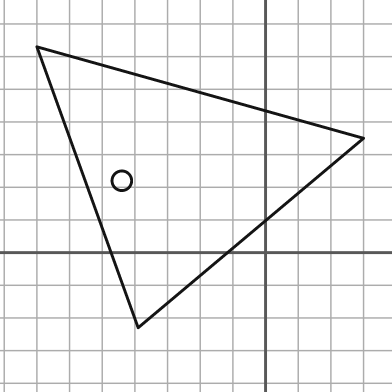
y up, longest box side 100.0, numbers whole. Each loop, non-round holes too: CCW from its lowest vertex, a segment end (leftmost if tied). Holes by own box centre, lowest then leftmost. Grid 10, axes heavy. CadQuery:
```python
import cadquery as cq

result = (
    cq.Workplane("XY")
    .moveTo(-39.0, -23.0)
    .lineTo(30.0, 35.0)
    .lineTo(-70.0, 63.0)
    .close()
    .moveTo(-44.0, 22.0)
    .circle(3.0)
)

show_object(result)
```